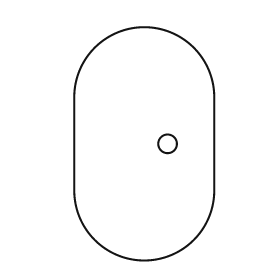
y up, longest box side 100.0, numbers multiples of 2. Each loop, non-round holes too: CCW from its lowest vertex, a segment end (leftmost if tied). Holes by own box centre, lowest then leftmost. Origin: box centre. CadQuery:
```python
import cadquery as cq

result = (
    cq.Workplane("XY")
    .moveTo(-30.0, -20.0)
    .threePointArc((0.0, -50.0), (30.0, -20.0))
    .lineTo(30.0, 20.0)
    .threePointArc((0.0, 50.0), (-30.0, 20.0))
    .close()
    .moveTo(10.0, 0.0)
    .circle(4.0)
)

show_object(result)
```